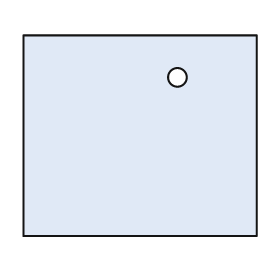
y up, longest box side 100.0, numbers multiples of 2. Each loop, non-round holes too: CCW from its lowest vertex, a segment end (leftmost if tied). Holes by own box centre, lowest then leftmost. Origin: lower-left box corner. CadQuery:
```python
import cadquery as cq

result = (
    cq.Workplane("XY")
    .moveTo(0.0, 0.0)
    .lineTo(100.0, 0.0)
    .lineTo(100.0, 86.0)
    .lineTo(0.0, 86.0)
    .close()
    .moveTo(66.0, 68.0)
    .circle(4.0)
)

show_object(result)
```